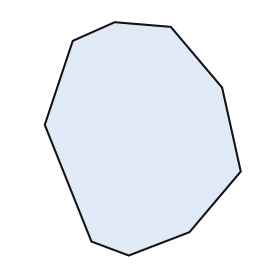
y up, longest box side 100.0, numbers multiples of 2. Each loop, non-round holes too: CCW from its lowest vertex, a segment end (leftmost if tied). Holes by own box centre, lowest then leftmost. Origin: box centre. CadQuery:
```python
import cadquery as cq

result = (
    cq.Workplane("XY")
    .moveTo(-6.0, -50.0)
    .lineTo(20.0, -40.0)
    .lineTo(42.0, -14.0)
    .lineTo(34.0, 22.0)
    .lineTo(12.0, 48.0)
    .lineTo(-12.0, 50.0)
    .lineTo(-30.0, 42.0)
    .lineTo(-42.0, 6.0)
    .lineTo(-22.0, -44.0)
    .close()
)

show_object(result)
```